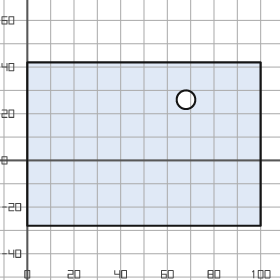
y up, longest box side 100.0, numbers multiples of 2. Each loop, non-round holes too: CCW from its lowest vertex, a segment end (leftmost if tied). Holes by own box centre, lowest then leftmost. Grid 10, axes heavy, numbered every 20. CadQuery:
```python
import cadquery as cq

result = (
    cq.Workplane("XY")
    .moveTo(0.0, -28.0)
    .lineTo(100.0, -28.0)
    .lineTo(100.0, 42.0)
    .lineTo(0.0, 42.0)
    .close()
    .moveTo(68.0, 26.0)
    .circle(4.0)
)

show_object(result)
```